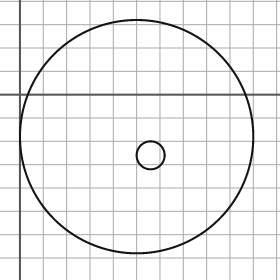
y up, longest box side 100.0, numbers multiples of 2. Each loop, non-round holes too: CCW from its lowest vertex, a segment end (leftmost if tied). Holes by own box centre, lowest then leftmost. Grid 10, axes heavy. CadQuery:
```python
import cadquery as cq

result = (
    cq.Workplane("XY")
    .moveTo(50.0, -18.0)
    .circle(50.0)
    .moveTo(56.0, -26.0)
    .circle(6.0)
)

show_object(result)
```